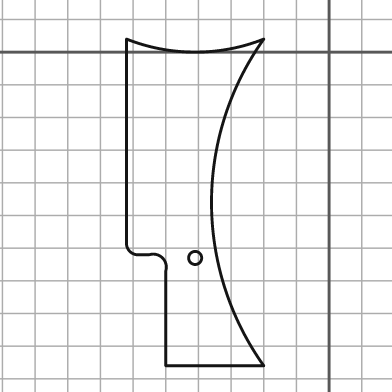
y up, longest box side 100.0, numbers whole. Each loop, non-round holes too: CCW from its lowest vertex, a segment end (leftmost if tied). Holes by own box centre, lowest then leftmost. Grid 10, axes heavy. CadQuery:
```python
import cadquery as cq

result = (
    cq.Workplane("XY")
    .moveTo(-50.0, -96.0)
    .lineTo(-20.0, -96.0)
    .threePointArc((-36.0, -46.0), (-20.0, 4.0))
    .threePointArc((-41.0, 0.0), (-62.0, 4.0))
    .lineTo(-62.0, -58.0)
    .threePointArc((-61.0, -61.0), (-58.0, -62.0))
    .lineTo(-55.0, -62.0)
    .threePointArc((-51.0, -63.0), (-50.0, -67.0))
    .close()
    .moveTo(-41.0, -63.0)
    .circle(2.0)
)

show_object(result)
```